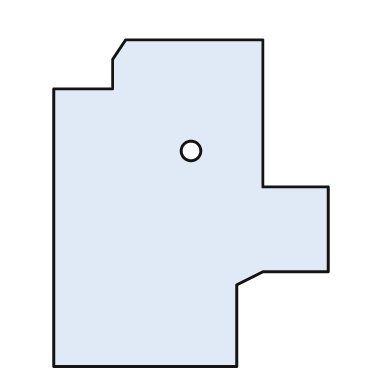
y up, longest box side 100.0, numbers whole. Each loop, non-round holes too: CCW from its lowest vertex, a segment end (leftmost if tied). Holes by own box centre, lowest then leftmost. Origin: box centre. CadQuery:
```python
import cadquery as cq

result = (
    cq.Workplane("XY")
    .moveTo(-42.0, -50.0)
    .lineTo(14.0, -50.0)
    .lineTo(14.0, -25.0)
    .lineTo(22.0, -21.0)
    .lineTo(42.0, -21.0)
    .lineTo(42.0, 5.0)
    .lineTo(22.0, 5.0)
    .lineTo(22.0, 50.0)
    .lineTo(-20.0, 50.0)
    .lineTo(-24.0, 44.0)
    .lineTo(-24.0, 35.0)
    .lineTo(-42.0, 35.0)
    .close()
    .moveTo(0.0, 16.0)
    .circle(3.0)
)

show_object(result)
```